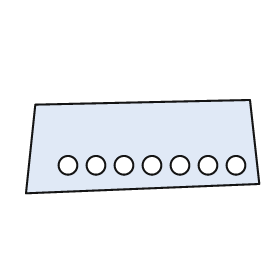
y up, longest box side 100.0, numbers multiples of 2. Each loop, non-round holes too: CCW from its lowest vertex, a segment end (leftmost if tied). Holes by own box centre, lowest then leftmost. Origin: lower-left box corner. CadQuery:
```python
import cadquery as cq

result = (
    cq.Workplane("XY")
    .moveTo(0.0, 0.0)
    .lineTo(100.0, 4.0)
    .lineTo(96.0, 40.0)
    .lineTo(4.0, 38.0)
    .close()
    .moveTo(18.0, 12.0)
    .circle(4.0)
    .moveTo(30.0, 12.0)
    .circle(4.0)
    .moveTo(42.0, 12.0)
    .circle(4.0)
    .moveTo(54.0, 12.0)
    .circle(4.0)
    .moveTo(66.0, 12.0)
    .circle(4.0)
    .moveTo(78.0, 12.0)
    .circle(4.0)
    .moveTo(90.0, 12.0)
    .circle(4.0)
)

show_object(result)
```